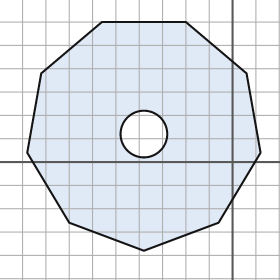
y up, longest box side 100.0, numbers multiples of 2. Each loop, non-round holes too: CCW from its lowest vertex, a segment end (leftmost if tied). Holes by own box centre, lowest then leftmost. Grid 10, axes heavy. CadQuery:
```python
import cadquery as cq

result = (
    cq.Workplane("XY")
    .moveTo(-38.0, -38.0)
    .lineTo(-6.0, -26.0)
    .lineTo(12.0, 4.0)
    .lineTo(6.0, 38.0)
    .lineTo(-20.0, 60.0)
    .lineTo(-56.0, 60.0)
    .lineTo(-82.0, 38.0)
    .lineTo(-88.0, 4.0)
    .lineTo(-70.0, -26.0)
    .close()
    .moveTo(-38.0, 12.0)
    .circle(10.0)
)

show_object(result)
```